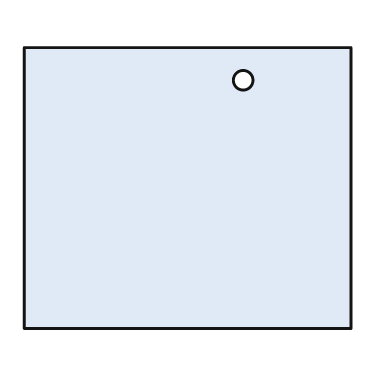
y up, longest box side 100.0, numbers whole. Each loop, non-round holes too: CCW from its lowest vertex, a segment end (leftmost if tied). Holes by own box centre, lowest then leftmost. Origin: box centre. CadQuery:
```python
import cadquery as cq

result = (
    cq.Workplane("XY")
    .moveTo(-50.0, -43.0)
    .lineTo(50.0, -43.0)
    .lineTo(50.0, 43.0)
    .lineTo(-50.0, 43.0)
    .close()
    .moveTo(17.0, 33.0)
    .circle(3.0)
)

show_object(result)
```